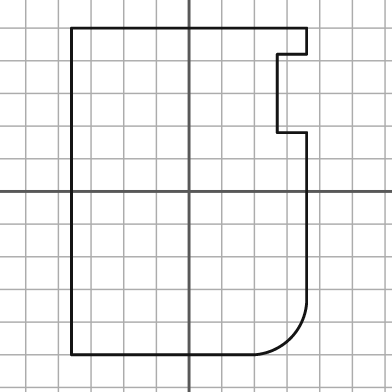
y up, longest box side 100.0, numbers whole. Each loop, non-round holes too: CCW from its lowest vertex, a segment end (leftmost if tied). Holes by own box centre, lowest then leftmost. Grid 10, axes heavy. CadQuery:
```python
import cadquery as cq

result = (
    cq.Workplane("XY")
    .moveTo(-36.0, -50.0)
    .lineTo(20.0, -50.0)
    .threePointArc((31.0, -45.0), (36.0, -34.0))
    .lineTo(36.0, 18.0)
    .lineTo(27.0, 18.0)
    .lineTo(27.0, 42.0)
    .lineTo(36.0, 42.0)
    .lineTo(36.0, 50.0)
    .lineTo(-36.0, 50.0)
    .close()
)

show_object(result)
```